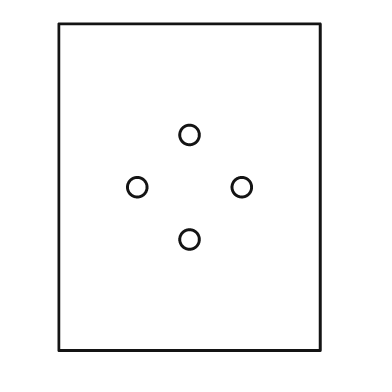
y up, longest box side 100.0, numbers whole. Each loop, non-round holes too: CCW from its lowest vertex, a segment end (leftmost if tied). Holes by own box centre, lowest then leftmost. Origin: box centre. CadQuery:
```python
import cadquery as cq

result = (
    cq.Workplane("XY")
    .moveTo(-40.0, -50.0)
    .lineTo(40.0, -50.0)
    .lineTo(40.0, 50.0)
    .lineTo(-40.0, 50.0)
    .close()
    .moveTo(0.0, -16.0)
    .circle(3.0)
    .moveTo(-16.0, 0.0)
    .circle(3.0)
    .moveTo(16.0, 0.0)
    .circle(3.0)
    .moveTo(0.0, 16.0)
    .circle(3.0)
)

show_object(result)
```